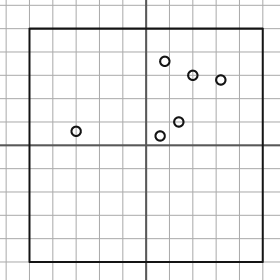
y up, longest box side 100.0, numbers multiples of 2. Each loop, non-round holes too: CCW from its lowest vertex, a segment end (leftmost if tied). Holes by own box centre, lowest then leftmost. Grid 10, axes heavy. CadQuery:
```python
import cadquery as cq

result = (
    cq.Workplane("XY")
    .moveTo(-50.0, -50.0)
    .lineTo(50.0, -50.0)
    .lineTo(50.0, 50.0)
    .lineTo(-50.0, 50.0)
    .close()
    .moveTo(6.0, 4.0)
    .circle(2.0)
    .moveTo(-30.0, 6.0)
    .circle(2.0)
    .moveTo(14.0, 10.0)
    .circle(2.0)
    .moveTo(32.0, 28.0)
    .circle(2.0)
    .moveTo(20.0, 30.0)
    .circle(2.0)
    .moveTo(8.0, 36.0)
    .circle(2.0)
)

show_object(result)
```